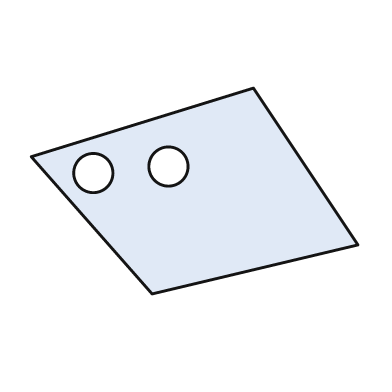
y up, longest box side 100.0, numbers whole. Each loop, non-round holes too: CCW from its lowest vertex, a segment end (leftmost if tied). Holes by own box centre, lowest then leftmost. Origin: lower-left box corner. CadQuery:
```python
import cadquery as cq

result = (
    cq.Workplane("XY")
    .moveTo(37.0, 0.0)
    .lineTo(100.0, 15.0)
    .lineTo(68.0, 63.0)
    .lineTo(0.0, 42.0)
    .close()
    .moveTo(19.0, 37.0)
    .circle(6.0)
    .moveTo(42.0, 39.0)
    .circle(6.0)
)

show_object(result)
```